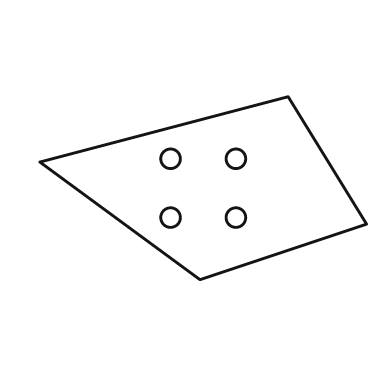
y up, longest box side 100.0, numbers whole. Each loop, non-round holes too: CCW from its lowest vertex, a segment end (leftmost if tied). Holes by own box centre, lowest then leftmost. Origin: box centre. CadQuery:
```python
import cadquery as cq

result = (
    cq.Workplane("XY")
    .moveTo(-1.0, -28.0)
    .lineTo(50.0, -11.0)
    .lineTo(26.0, 28.0)
    .lineTo(-50.0, 8.0)
    .close()
    .moveTo(-10.0, -9.0)
    .circle(3.0)
    .moveTo(10.0, -9.0)
    .circle(3.0)
    .moveTo(-10.0, 9.0)
    .circle(3.0)
    .moveTo(10.0, 9.0)
    .circle(3.0)
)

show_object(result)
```